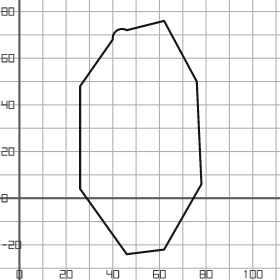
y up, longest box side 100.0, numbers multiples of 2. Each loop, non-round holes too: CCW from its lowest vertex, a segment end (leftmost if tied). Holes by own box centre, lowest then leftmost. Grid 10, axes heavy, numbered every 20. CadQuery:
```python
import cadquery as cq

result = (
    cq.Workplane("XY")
    .moveTo(46.0, -24.0)
    .lineTo(62.0, -22.0)
    .lineTo(78.0, 6.0)
    .lineTo(76.0, 50.0)
    .lineTo(62.0, 76.0)
    .lineTo(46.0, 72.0)
    .threePointArc((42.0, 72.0), (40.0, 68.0))
    .lineTo(26.0, 48.0)
    .lineTo(26.0, 4.0)
    .close()
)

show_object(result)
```